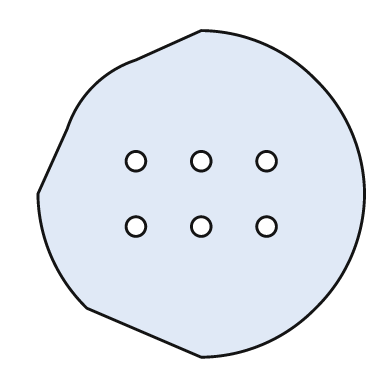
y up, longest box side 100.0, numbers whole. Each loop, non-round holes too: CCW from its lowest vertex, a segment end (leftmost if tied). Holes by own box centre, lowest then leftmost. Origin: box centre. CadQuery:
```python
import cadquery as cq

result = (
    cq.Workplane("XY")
    .moveTo(0.0, -50.0)
    .threePointArc((19.0, -46.0), (35.0, -35.0))
    .threePointArc((46.0, -19.0), (50.0, 0.0))
    .threePointArc((46.0, 19.0), (35.0, 35.0))
    .threePointArc((19.0, 46.0), (0.0, 50.0))
    .lineTo(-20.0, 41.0)
    .threePointArc((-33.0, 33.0), (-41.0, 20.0))
    .lineTo(-50.0, 0.0)
    .threePointArc((-46.0, -19.0), (-35.0, -35.0))
    .close()
    .moveTo(-20.0, -10.0)
    .circle(3.0)
    .moveTo(0.0, -10.0)
    .circle(3.0)
    .moveTo(20.0, -10.0)
    .circle(3.0)
    .moveTo(-20.0, 10.0)
    .circle(3.0)
    .moveTo(0.0, 10.0)
    .circle(3.0)
    .moveTo(20.0, 10.0)
    .circle(3.0)
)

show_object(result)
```